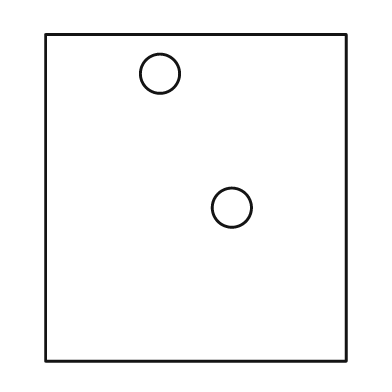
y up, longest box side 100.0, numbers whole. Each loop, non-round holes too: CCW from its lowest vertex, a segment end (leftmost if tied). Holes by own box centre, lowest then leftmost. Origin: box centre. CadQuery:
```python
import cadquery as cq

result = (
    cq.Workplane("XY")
    .moveTo(-46.0, -50.0)
    .lineTo(46.0, -50.0)
    .lineTo(46.0, 50.0)
    .lineTo(-46.0, 50.0)
    .close()
    .moveTo(11.0, -3.0)
    .circle(6.0)
    .moveTo(-11.0, 38.0)
    .circle(6.0)
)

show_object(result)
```